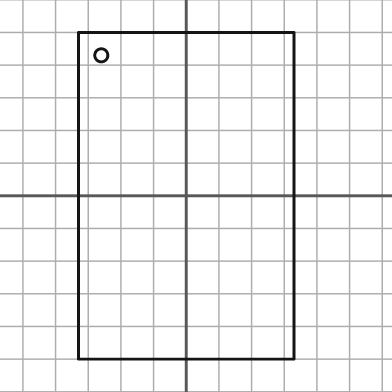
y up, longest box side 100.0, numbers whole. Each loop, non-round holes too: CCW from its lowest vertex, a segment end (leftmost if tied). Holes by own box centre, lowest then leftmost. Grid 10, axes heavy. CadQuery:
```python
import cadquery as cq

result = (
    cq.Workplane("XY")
    .moveTo(-33.0, -50.0)
    .lineTo(33.0, -50.0)
    .lineTo(33.0, 50.0)
    .lineTo(-33.0, 50.0)
    .close()
    .moveTo(-26.0, 43.0)
    .circle(2.0)
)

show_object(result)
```